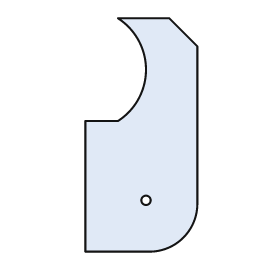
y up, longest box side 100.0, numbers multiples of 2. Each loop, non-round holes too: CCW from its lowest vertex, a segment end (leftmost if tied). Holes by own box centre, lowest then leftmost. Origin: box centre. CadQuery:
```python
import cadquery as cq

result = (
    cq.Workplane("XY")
    .moveTo(-24.0, -50.0)
    .lineTo(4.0, -50.0)
    .threePointArc((18.0, -44.0), (24.0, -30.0))
    .lineTo(24.0, 38.0)
    .lineTo(12.0, 50.0)
    .lineTo(-10.0, 50.0)
    .threePointArc((2.0, 28.0), (-10.0, 6.0))
    .lineTo(-24.0, 6.0)
    .close()
    .moveTo(2.0, -28.0)
    .circle(2.0)
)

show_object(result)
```